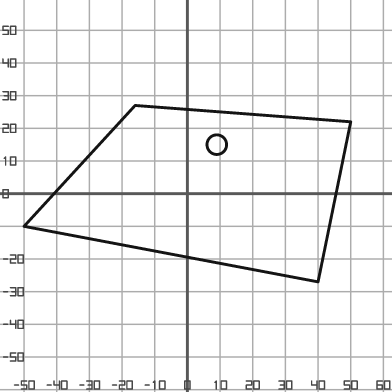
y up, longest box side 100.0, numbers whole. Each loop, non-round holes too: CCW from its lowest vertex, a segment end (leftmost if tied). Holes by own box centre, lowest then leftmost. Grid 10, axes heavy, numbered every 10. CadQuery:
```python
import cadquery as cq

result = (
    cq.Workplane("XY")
    .moveTo(40.0, -27.0)
    .lineTo(50.0, 22.0)
    .lineTo(-16.0, 27.0)
    .lineTo(-50.0, -10.0)
    .close()
    .moveTo(9.0, 15.0)
    .circle(3.0)
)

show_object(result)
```